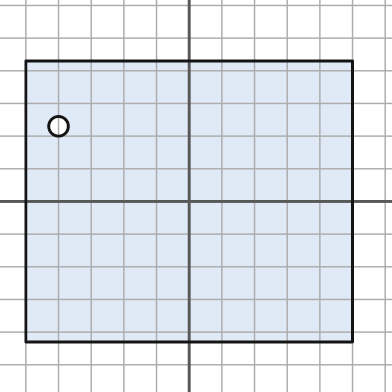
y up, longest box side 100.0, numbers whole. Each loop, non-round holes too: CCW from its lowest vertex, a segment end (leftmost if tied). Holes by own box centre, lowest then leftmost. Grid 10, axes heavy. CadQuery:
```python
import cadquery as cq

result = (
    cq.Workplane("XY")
    .moveTo(-50.0, -43.0)
    .lineTo(50.0, -43.0)
    .lineTo(50.0, 43.0)
    .lineTo(-50.0, 43.0)
    .close()
    .moveTo(-40.0, 23.0)
    .circle(3.0)
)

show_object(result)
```